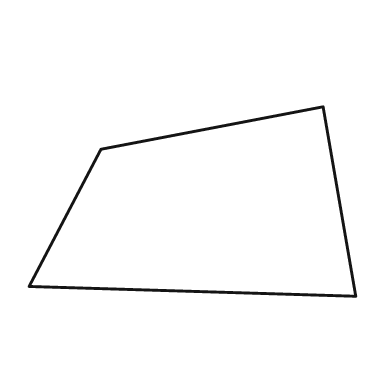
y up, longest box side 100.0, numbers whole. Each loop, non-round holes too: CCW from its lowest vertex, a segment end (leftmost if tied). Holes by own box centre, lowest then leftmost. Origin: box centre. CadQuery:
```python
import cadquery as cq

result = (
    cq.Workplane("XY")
    .moveTo(50.0, -29.0)
    .lineTo(40.0, 29.0)
    .lineTo(-28.0, 16.0)
    .lineTo(-50.0, -26.0)
    .close()
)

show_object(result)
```